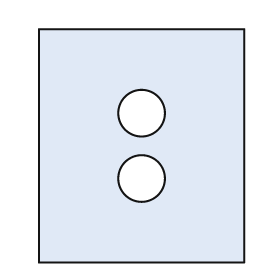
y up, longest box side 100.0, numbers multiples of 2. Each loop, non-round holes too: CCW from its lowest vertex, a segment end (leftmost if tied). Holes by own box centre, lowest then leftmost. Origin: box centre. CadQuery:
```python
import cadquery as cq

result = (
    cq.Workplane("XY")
    .moveTo(-44.0, -50.0)
    .lineTo(44.0, -50.0)
    .lineTo(44.0, 50.0)
    .lineTo(-44.0, 50.0)
    .close()
    .moveTo(0.0, -14.0)
    .circle(10.0)
    .moveTo(0.0, 14.0)
    .circle(10.0)
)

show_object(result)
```